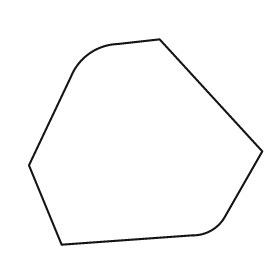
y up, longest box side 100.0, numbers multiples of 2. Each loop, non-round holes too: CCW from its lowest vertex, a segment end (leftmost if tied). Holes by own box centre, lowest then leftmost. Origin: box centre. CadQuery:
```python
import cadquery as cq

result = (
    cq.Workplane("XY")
    .moveTo(-36.0, -44.0)
    .lineTo(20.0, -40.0)
    .threePointArc((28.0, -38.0), (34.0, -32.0))
    .lineTo(50.0, -4.0)
    .lineTo(6.0, 44.0)
    .lineTo(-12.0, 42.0)
    .threePointArc((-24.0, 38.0), (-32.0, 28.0))
    .lineTo(-50.0, -10.0)
    .close()
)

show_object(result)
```